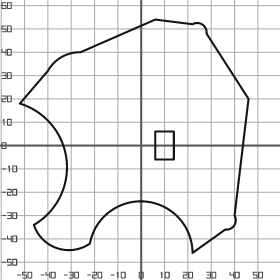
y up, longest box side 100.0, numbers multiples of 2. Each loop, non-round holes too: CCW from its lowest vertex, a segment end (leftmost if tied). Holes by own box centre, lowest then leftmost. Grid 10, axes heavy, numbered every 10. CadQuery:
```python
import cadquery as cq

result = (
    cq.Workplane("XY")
    .moveTo(22.0, -46.0)
    .lineTo(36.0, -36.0)
    .threePointArc((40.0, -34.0), (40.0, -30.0))
    .lineTo(46.0, 20.0)
    .lineTo(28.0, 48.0)
    .threePointArc((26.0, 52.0), (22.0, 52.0))
    .lineTo(6.0, 54.0)
    .lineTo(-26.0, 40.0)
    .threePointArc((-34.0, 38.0), (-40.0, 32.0))
    .lineTo(-52.0, 18.0)
    .threePointArc((-32.0, -6.0), (-46.0, -34.0))
    .threePointArc((-36.0, -44.0), (-22.0, -42.0))
    .threePointArc((2.0, -24.0), (22.0, -46.0))
    .close()
    .moveTo(6.0, -6.0)
    .lineTo(14.0, -6.0)
    .lineTo(14.0, 6.0)
    .lineTo(6.0, 6.0)
    .close()
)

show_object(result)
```